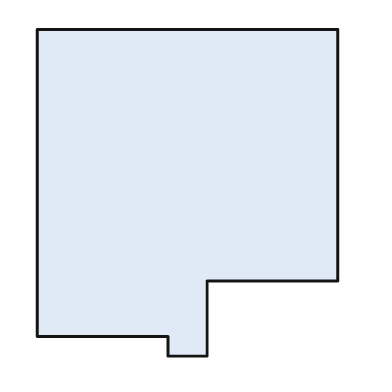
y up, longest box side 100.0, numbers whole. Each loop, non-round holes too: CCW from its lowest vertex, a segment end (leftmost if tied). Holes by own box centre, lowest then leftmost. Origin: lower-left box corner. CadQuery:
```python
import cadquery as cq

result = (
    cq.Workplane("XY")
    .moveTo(40.0, 0.0)
    .lineTo(52.0, 0.0)
    .lineTo(52.0, 23.0)
    .lineTo(92.0, 23.0)
    .lineTo(92.0, 100.0)
    .lineTo(0.0, 100.0)
    .lineTo(0.0, 6.0)
    .lineTo(40.0, 6.0)
    .close()
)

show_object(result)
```